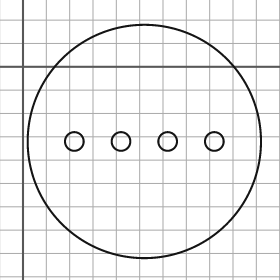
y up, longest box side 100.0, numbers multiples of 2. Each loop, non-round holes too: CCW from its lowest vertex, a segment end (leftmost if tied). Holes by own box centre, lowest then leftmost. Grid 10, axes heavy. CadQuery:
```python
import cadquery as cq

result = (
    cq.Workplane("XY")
    .moveTo(52.0, -32.0)
    .circle(50.0)
    .moveTo(22.0, -32.0)
    .circle(4.0)
    .moveTo(42.0, -32.0)
    .circle(4.0)
    .moveTo(62.0, -32.0)
    .circle(4.0)
    .moveTo(82.0, -32.0)
    .circle(4.0)
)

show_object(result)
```